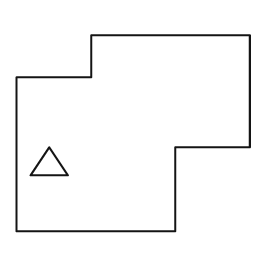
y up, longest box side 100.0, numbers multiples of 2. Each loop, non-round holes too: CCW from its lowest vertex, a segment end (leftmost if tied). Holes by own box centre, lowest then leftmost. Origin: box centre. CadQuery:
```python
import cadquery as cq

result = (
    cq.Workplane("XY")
    .moveTo(-50.0, -42.0)
    .lineTo(18.0, -42.0)
    .lineTo(18.0, -6.0)
    .lineTo(50.0, -6.0)
    .lineTo(50.0, 42.0)
    .lineTo(-18.0, 42.0)
    .lineTo(-18.0, 24.0)
    .lineTo(-50.0, 24.0)
    .close()
    .moveTo(-44.0, -18.0)
    .lineTo(-28.0, -18.0)
    .lineTo(-36.0, -6.0)
    .close()
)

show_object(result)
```